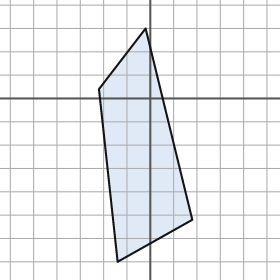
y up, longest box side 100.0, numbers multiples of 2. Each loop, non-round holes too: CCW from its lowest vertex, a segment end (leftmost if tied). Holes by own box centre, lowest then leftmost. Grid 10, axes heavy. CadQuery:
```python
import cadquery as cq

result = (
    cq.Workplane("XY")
    .moveTo(-14.0, -70.0)
    .lineTo(18.0, -52.0)
    .lineTo(-2.0, 30.0)
    .lineTo(-22.0, 4.0)
    .close()
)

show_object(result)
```